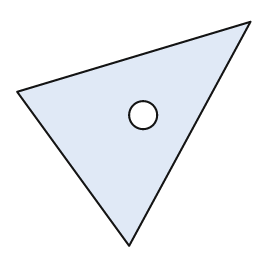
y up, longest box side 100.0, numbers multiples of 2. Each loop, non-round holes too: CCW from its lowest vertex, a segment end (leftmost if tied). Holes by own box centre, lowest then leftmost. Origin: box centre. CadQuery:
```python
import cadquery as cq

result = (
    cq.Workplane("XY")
    .moveTo(-2.0, -48.0)
    .lineTo(50.0, 48.0)
    .lineTo(-50.0, 18.0)
    .close()
    .moveTo(4.0, 8.0)
    .circle(6.0)
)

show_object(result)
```